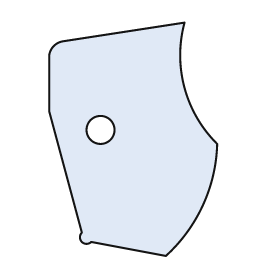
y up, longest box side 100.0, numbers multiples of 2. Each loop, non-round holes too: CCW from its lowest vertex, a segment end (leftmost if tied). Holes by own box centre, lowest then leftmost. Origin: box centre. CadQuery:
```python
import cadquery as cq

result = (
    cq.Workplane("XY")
    .moveTo(14.0, -50.0)
    .threePointArc((30.0, -28.0), (36.0, -2.0))
    .threePointArc((22.0, 22.0), (22.0, 50.0))
    .lineTo(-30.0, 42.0)
    .threePointArc((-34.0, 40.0), (-36.0, 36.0))
    .lineTo(-36.0, 12.0)
    .lineTo(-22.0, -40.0)
    .threePointArc((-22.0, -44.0), (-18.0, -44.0))
    .close()
    .moveTo(-14.0, 4.0)
    .circle(6.0)
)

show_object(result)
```